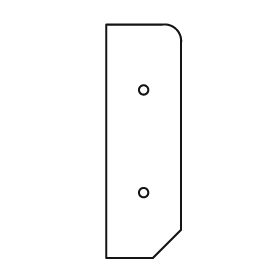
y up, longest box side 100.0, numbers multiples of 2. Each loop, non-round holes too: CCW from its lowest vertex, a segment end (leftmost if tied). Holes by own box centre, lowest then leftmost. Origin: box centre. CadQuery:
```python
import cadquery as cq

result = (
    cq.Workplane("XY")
    .moveTo(-16.0, -50.0)
    .lineTo(4.0, -50.0)
    .lineTo(16.0, -38.0)
    .lineTo(16.0, 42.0)
    .threePointArc((14.0, 48.0), (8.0, 50.0))
    .lineTo(-16.0, 50.0)
    .close()
    .moveTo(0.0, -22.0)
    .circle(2.0)
    .moveTo(0.0, 22.0)
    .circle(2.0)
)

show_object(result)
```